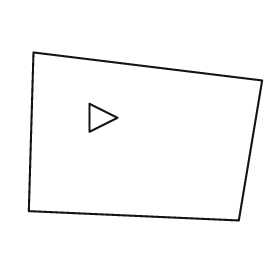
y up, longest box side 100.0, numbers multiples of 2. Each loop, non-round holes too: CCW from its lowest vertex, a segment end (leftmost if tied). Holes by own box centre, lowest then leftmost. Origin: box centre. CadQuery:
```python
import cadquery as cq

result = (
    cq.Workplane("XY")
    .moveTo(40.0, -36.0)
    .lineTo(50.0, 24.0)
    .lineTo(-48.0, 36.0)
    .lineTo(-50.0, -32.0)
    .close()
    .moveTo(-24.0, 2.0)
    .lineTo(-12.0, 8.0)
    .lineTo(-24.0, 14.0)
    .close()
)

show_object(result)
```